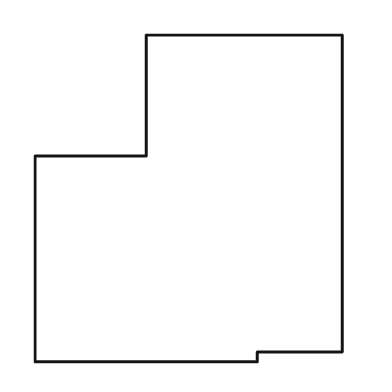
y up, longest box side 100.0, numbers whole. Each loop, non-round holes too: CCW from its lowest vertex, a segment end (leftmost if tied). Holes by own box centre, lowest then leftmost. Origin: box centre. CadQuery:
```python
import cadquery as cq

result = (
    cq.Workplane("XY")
    .moveTo(-47.0, -50.0)
    .lineTo(21.0, -50.0)
    .lineTo(21.0, -47.0)
    .lineTo(47.0, -47.0)
    .lineTo(47.0, 50.0)
    .lineTo(-13.0, 50.0)
    .lineTo(-13.0, 13.0)
    .lineTo(-47.0, 13.0)
    .close()
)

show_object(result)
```